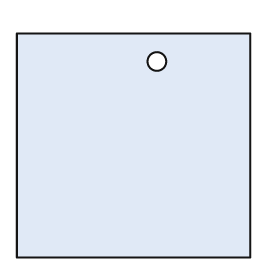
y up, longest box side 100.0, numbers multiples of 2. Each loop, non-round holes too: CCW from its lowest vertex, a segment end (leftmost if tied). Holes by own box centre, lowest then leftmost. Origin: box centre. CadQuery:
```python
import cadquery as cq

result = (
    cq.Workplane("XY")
    .moveTo(-50.0, -48.0)
    .lineTo(50.0, -48.0)
    .lineTo(50.0, 48.0)
    .lineTo(-50.0, 48.0)
    .close()
    .moveTo(10.0, 36.0)
    .circle(4.0)
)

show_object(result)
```